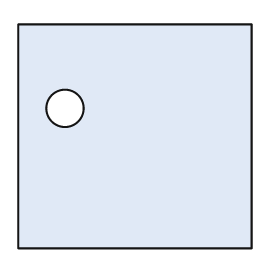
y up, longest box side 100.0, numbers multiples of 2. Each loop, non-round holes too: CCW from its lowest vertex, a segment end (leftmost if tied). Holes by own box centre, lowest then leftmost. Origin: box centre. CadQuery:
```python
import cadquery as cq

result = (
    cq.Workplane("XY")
    .moveTo(-50.0, -48.0)
    .lineTo(50.0, -48.0)
    .lineTo(50.0, 48.0)
    .lineTo(-50.0, 48.0)
    .close()
    .moveTo(-30.0, 12.0)
    .circle(8.0)
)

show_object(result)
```